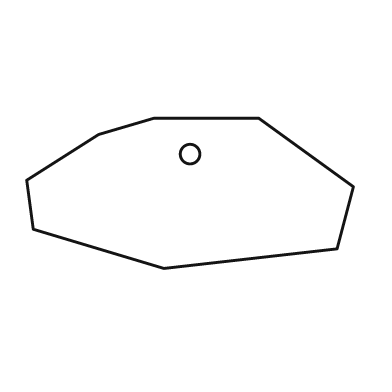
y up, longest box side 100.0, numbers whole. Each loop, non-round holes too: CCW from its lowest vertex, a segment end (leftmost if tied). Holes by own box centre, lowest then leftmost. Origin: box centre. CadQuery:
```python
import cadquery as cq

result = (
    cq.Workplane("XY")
    .moveTo(-8.0, -23.0)
    .lineTo(45.0, -17.0)
    .lineTo(50.0, 2.0)
    .lineTo(21.0, 23.0)
    .lineTo(-11.0, 23.0)
    .lineTo(-28.0, 18.0)
    .lineTo(-50.0, 4.0)
    .lineTo(-48.0, -11.0)
    .close()
    .moveTo(0.0, 12.0)
    .circle(3.0)
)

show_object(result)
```